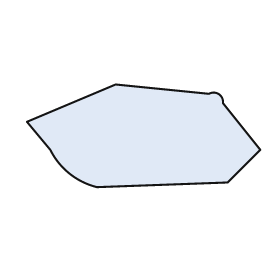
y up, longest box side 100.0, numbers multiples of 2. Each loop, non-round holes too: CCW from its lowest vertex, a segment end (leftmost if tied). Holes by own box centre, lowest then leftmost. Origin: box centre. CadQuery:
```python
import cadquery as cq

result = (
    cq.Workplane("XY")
    .moveTo(-20.0, -22.0)
    .lineTo(36.0, -20.0)
    .lineTo(50.0, -6.0)
    .lineTo(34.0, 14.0)
    .threePointArc((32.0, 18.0), (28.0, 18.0))
    .lineTo(-12.0, 22.0)
    .lineTo(-50.0, 6.0)
    .lineTo(-40.0, -6.0)
    .threePointArc((-32.0, -16.0), (-20.0, -22.0))
    .close()
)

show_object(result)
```